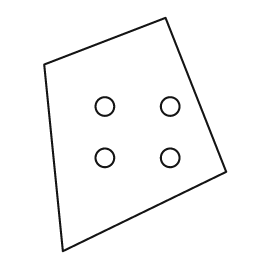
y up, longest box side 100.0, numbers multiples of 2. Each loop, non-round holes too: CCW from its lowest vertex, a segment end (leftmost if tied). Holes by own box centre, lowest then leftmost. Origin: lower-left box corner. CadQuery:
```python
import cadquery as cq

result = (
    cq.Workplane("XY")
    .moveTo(8.0, 0.0)
    .lineTo(78.0, 34.0)
    .lineTo(52.0, 100.0)
    .lineTo(0.0, 80.0)
    .close()
    .moveTo(26.0, 40.0)
    .circle(4.0)
    .moveTo(54.0, 40.0)
    .circle(4.0)
    .moveTo(26.0, 62.0)
    .circle(4.0)
    .moveTo(54.0, 62.0)
    .circle(4.0)
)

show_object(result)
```